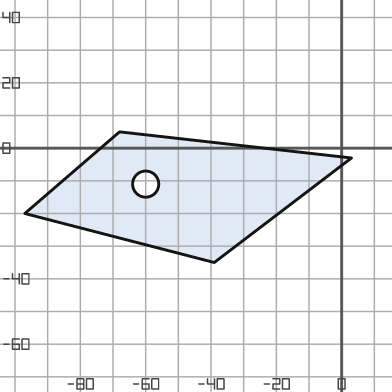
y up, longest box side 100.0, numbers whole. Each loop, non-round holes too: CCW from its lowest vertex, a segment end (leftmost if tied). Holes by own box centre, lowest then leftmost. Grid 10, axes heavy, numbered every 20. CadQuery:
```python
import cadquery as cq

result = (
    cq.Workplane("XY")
    .moveTo(-39.0, -35.0)
    .lineTo(3.0, -3.0)
    .lineTo(-68.0, 5.0)
    .lineTo(-97.0, -20.0)
    .close()
    .moveTo(-60.0, -11.0)
    .circle(4.0)
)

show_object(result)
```